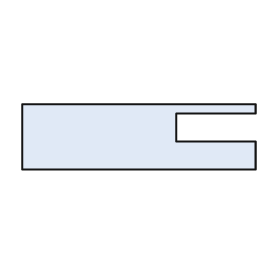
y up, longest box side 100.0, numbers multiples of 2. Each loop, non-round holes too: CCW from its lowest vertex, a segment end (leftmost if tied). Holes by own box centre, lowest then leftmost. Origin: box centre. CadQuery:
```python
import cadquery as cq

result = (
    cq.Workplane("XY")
    .moveTo(-50.0, -14.0)
    .lineTo(50.0, -14.0)
    .lineTo(50.0, -2.0)
    .lineTo(16.0, -2.0)
    .lineTo(16.0, 10.0)
    .lineTo(50.0, 10.0)
    .lineTo(50.0, 14.0)
    .lineTo(-50.0, 14.0)
    .close()
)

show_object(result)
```